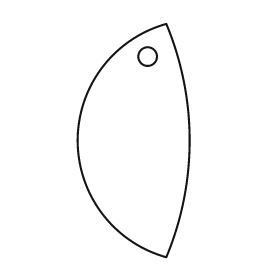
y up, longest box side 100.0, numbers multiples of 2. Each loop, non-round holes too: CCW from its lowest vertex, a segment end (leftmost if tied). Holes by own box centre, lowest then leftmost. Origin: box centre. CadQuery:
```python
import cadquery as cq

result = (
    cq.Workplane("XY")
    .moveTo(14.0, -50.0)
    .threePointArc((24.0, 0.0), (14.0, 50.0))
    .threePointArc((-24.0, 0.0), (14.0, -50.0))
    .close()
    .moveTo(6.0, 36.0)
    .circle(4.0)
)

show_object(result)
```